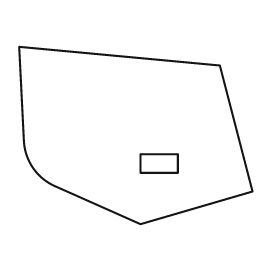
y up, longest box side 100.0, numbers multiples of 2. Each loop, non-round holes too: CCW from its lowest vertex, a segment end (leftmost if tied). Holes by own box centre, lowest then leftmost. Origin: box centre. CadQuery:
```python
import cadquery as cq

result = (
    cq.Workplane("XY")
    .moveTo(2.0, -38.0)
    .lineTo(50.0, -24.0)
    .lineTo(36.0, 30.0)
    .lineTo(-50.0, 38.0)
    .lineTo(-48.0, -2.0)
    .threePointArc((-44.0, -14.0), (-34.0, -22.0))
    .close()
    .moveTo(2.0, -16.0)
    .lineTo(18.0, -16.0)
    .lineTo(18.0, -8.0)
    .lineTo(2.0, -8.0)
    .close()
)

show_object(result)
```